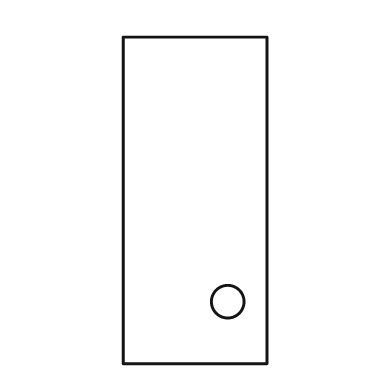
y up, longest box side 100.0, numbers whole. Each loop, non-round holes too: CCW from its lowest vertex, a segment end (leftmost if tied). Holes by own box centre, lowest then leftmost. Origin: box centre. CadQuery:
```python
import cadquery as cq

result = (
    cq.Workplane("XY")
    .moveTo(-22.0, -50.0)
    .lineTo(22.0, -50.0)
    .lineTo(22.0, 50.0)
    .lineTo(-22.0, 50.0)
    .close()
    .moveTo(10.0, -31.0)
    .circle(5.0)
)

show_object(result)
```